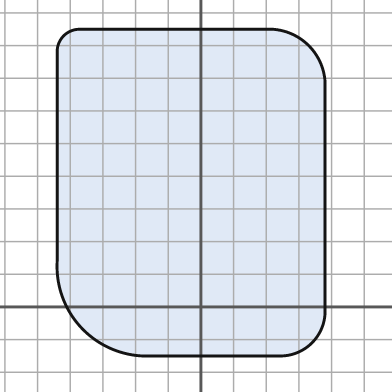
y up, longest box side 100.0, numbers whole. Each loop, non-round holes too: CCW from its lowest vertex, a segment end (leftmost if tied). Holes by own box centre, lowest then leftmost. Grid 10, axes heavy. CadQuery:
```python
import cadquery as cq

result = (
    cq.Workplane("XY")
    .moveTo(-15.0, -15.0)
    .lineTo(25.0, -15.0)
    .threePointArc((34.0, -11.0), (38.0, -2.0))
    .lineTo(38.0, 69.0)
    .threePointArc((33.0, 80.0), (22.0, 85.0))
    .lineTo(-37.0, 85.0)
    .threePointArc((-42.0, 83.0), (-44.0, 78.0))
    .lineTo(-44.0, 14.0)
    .threePointArc((-36.0, -7.0), (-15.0, -15.0))
    .close()
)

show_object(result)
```